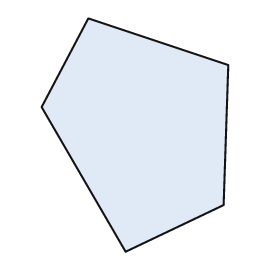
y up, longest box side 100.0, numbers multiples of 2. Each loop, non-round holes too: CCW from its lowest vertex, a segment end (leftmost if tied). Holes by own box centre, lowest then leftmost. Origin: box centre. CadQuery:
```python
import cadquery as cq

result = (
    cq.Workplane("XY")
    .moveTo(-4.0, -50.0)
    .lineTo(38.0, -30.0)
    .lineTo(40.0, 30.0)
    .lineTo(-20.0, 50.0)
    .lineTo(-40.0, 12.0)
    .close()
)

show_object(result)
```